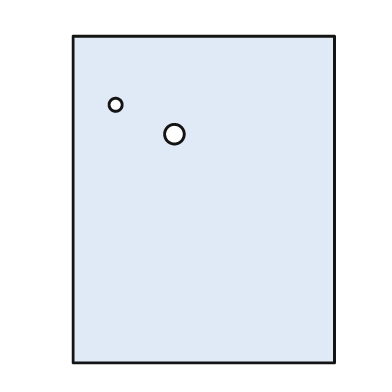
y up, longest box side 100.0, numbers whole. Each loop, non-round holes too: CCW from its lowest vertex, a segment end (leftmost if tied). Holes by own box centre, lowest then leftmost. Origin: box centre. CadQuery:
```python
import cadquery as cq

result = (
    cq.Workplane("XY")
    .moveTo(-40.0, -50.0)
    .lineTo(40.0, -50.0)
    .lineTo(40.0, 50.0)
    .lineTo(-40.0, 50.0)
    .close()
    .moveTo(-9.0, 20.0)
    .circle(3.0)
    .moveTo(-27.0, 29.0)
    .circle(2.0)
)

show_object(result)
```